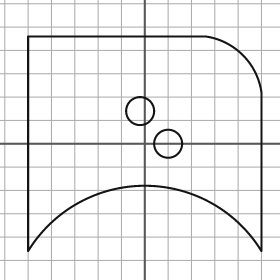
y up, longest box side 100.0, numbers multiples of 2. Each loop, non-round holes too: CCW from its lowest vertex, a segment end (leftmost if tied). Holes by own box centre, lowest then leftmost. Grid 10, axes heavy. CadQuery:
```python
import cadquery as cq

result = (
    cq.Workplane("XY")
    .moveTo(-50.0, -46.0)
    .threePointArc((0.0, -18.0), (50.0, -46.0))
    .lineTo(50.0, 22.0)
    .threePointArc((42.0, 38.0), (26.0, 46.0))
    .lineTo(-50.0, 46.0)
    .close()
    .moveTo(10.0, 0.0)
    .circle(6.0)
    .moveTo(-2.0, 14.0)
    .circle(6.0)
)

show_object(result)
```